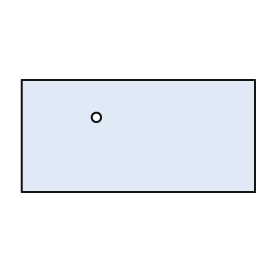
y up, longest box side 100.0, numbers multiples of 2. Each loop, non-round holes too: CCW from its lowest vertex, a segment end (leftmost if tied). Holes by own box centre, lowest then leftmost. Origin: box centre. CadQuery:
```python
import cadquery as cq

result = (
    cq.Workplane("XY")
    .moveTo(-50.0, -24.0)
    .lineTo(50.0, -24.0)
    .lineTo(50.0, 24.0)
    .lineTo(-50.0, 24.0)
    .close()
    .moveTo(-18.0, 8.0)
    .circle(2.0)
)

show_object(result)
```